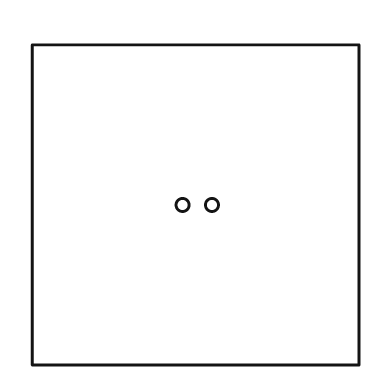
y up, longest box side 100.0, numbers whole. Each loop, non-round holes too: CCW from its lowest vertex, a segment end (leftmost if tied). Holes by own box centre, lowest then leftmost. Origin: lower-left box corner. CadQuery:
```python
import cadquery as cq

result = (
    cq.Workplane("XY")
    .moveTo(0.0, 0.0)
    .lineTo(100.0, 0.0)
    .lineTo(100.0, 98.0)
    .lineTo(0.0, 98.0)
    .close()
    .moveTo(46.0, 49.0)
    .circle(2.0)
    .moveTo(55.0, 49.0)
    .circle(2.0)
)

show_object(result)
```